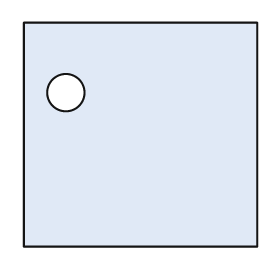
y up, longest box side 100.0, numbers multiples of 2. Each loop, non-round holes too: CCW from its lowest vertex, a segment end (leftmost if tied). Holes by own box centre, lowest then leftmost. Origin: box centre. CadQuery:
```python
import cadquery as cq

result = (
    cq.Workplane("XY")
    .moveTo(-50.0, -48.0)
    .lineTo(50.0, -48.0)
    .lineTo(50.0, 48.0)
    .lineTo(-50.0, 48.0)
    .close()
    .moveTo(-32.0, 18.0)
    .circle(8.0)
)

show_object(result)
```